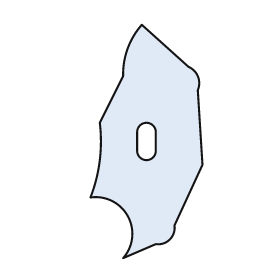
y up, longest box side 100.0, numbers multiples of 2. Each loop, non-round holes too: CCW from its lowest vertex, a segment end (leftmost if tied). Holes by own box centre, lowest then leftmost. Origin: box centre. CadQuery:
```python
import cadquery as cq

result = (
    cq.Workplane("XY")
    .moveTo(-10.0, -50.0)
    .lineTo(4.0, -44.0)
    .threePointArc((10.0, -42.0), (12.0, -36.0))
    .lineTo(24.0, -10.0)
    .lineTo(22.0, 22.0)
    .threePointArc((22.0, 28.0), (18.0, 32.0))
    .lineTo(-2.0, 50.0)
    .threePointArc((-8.0, 40.0), (-10.0, 28.0))
    .lineTo(-20.0, 8.0)
    .threePointArc((-20.0, -8.0), (-24.0, -24.0))
    .threePointArc((-8.0, -32.0), (-10.0, -50.0))
    .close()
    .moveTo(-4.0, -4.0)
    .threePointArc((0.0, -8.0), (4.0, -4.0))
    .lineTo(4.0, 4.0)
    .threePointArc((0.0, 8.0), (-4.0, 4.0))
    .close()
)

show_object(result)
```